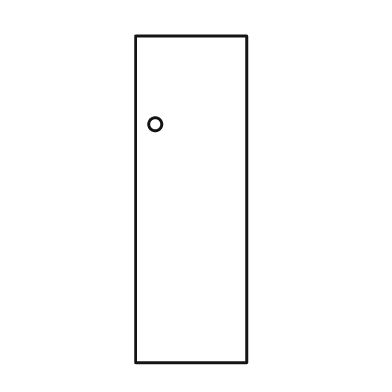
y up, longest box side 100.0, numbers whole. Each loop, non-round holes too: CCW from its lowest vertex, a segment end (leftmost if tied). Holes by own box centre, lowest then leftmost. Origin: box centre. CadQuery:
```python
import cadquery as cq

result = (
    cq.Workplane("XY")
    .moveTo(-17.0, -50.0)
    .lineTo(17.0, -50.0)
    .lineTo(17.0, 50.0)
    .lineTo(-17.0, 50.0)
    .close()
    .moveTo(-11.0, 23.0)
    .circle(2.0)
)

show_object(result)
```